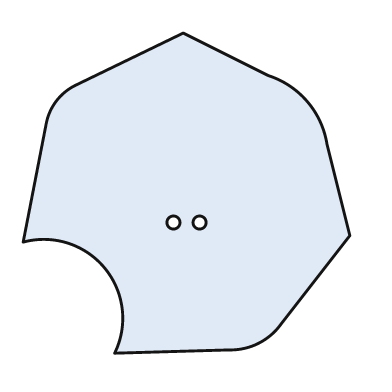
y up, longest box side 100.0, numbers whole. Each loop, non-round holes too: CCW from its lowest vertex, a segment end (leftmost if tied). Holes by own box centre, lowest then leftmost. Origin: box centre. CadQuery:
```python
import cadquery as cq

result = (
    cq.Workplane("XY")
    .moveTo(-22.0, -49.0)
    .lineTo(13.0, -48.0)
    .threePointArc((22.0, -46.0), (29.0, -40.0))
    .lineTo(50.0, -13.0)
    .lineTo(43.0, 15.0)
    .threePointArc((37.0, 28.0), (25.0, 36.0))
    .lineTo(-1.0, 49.0)
    .lineTo(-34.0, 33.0)
    .threePointArc((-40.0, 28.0), (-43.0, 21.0))
    .lineTo(-50.0, -15.0)
    .threePointArc((-25.0, -23.0), (-22.0, -49.0))
    .close()
    .moveTo(-4.0, -9.0)
    .circle(2.0)
    .moveTo(4.0, -9.0)
    .circle(2.0)
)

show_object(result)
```